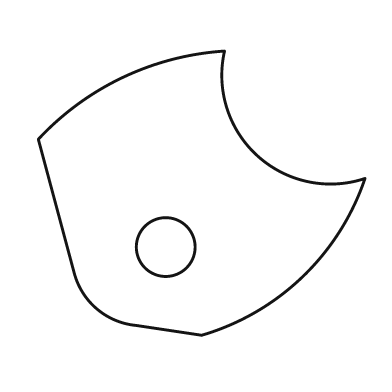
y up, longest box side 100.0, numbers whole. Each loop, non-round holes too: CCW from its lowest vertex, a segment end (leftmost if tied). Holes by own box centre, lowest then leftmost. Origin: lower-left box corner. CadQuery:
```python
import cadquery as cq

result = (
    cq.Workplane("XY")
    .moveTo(50.0, 0.0)
    .threePointArc((81.0, 18.0), (100.0, 48.0))
    .threePointArc((67.0, 55.0), (57.0, 87.0))
    .threePointArc((26.0, 79.0), (0.0, 60.0))
    .lineTo(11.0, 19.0)
    .threePointArc((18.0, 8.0), (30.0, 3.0))
    .close()
    .moveTo(39.0, 27.0)
    .circle(9.0)
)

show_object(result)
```